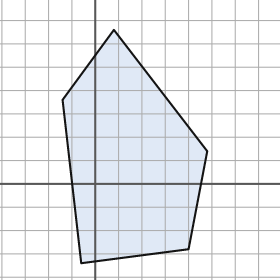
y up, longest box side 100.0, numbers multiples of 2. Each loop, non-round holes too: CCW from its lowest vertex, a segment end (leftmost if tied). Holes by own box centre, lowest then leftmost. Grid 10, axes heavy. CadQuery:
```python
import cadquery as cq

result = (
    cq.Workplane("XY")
    .moveTo(-6.0, -34.0)
    .lineTo(40.0, -28.0)
    .lineTo(48.0, 14.0)
    .lineTo(8.0, 66.0)
    .lineTo(-14.0, 36.0)
    .close()
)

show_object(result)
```